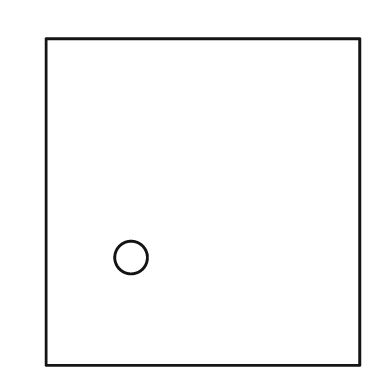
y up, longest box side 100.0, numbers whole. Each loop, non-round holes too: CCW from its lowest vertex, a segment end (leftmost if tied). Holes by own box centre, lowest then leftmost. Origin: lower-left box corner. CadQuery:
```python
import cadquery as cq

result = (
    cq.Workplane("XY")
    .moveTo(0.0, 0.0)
    .lineTo(96.0, 0.0)
    .lineTo(96.0, 100.0)
    .lineTo(0.0, 100.0)
    .close()
    .moveTo(26.0, 33.0)
    .circle(5.0)
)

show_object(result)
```